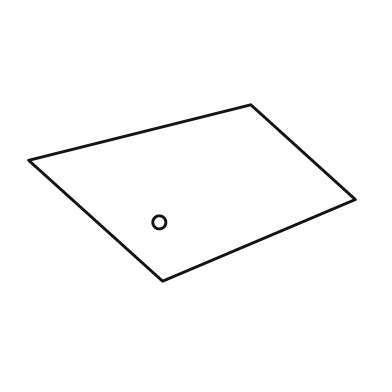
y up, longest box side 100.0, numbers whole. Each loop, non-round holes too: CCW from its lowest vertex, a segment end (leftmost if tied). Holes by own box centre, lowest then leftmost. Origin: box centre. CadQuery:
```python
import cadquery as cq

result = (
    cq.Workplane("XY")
    .moveTo(-9.0, -27.0)
    .lineTo(50.0, -2.0)
    .lineTo(18.0, 27.0)
    .lineTo(-50.0, 10.0)
    .close()
    .moveTo(-10.0, -9.0)
    .circle(2.0)
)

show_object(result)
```